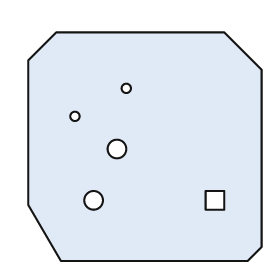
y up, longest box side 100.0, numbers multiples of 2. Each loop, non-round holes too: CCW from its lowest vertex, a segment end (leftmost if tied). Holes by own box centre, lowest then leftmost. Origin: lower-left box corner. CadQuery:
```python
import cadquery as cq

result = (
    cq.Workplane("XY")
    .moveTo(14.0, 0.0)
    .lineTo(94.0, 0.0)
    .lineTo(100.0, 6.0)
    .lineTo(100.0, 82.0)
    .lineTo(84.0, 98.0)
    .lineTo(12.0, 98.0)
    .lineTo(0.0, 86.0)
    .lineTo(0.0, 24.0)
    .close()
    .moveTo(28.0, 26.0)
    .circle(4.0)
    .moveTo(76.0, 22.0)
    .lineTo(84.0, 22.0)
    .lineTo(84.0, 30.0)
    .lineTo(76.0, 30.0)
    .close()
    .moveTo(38.0, 48.0)
    .circle(4.0)
    .moveTo(20.0, 62.0)
    .circle(2.0)
    .moveTo(42.0, 74.0)
    .circle(2.0)
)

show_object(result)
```